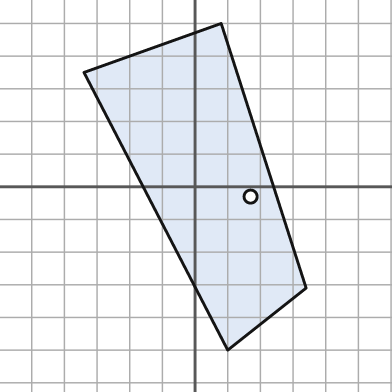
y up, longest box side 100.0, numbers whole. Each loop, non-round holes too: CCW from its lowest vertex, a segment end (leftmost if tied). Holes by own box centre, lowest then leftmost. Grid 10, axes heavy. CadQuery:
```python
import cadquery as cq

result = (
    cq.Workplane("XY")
    .moveTo(10.0, -50.0)
    .lineTo(34.0, -31.0)
    .lineTo(8.0, 50.0)
    .lineTo(-34.0, 35.0)
    .close()
    .moveTo(17.0, -3.0)
    .circle(2.0)
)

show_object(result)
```